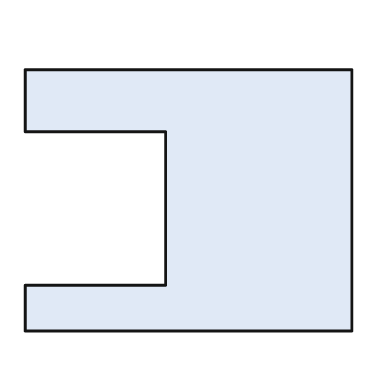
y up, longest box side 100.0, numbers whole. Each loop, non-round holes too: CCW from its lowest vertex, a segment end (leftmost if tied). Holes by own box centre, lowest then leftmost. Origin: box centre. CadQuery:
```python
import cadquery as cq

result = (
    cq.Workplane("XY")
    .moveTo(-50.0, -40.0)
    .lineTo(50.0, -40.0)
    .lineTo(50.0, 40.0)
    .lineTo(-50.0, 40.0)
    .lineTo(-50.0, 21.0)
    .lineTo(-7.0, 21.0)
    .lineTo(-7.0, -26.0)
    .lineTo(-50.0, -26.0)
    .close()
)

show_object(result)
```